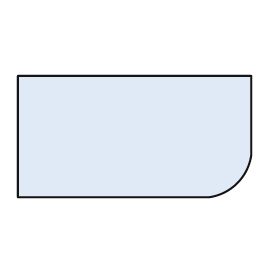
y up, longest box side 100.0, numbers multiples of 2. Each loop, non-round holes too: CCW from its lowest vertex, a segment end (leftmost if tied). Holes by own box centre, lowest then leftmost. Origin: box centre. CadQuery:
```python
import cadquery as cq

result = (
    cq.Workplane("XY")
    .moveTo(-50.0, -26.0)
    .lineTo(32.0, -26.0)
    .threePointArc((44.0, -20.0), (50.0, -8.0))
    .lineTo(50.0, 26.0)
    .lineTo(-50.0, 26.0)
    .close()
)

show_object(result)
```